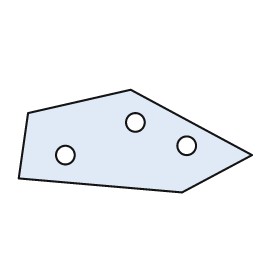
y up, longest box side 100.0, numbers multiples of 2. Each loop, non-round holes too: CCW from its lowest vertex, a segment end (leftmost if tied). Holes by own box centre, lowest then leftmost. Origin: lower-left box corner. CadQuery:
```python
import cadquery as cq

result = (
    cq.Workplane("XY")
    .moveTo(70.0, 0.0)
    .lineTo(100.0, 16.0)
    .lineTo(48.0, 44.0)
    .lineTo(4.0, 34.0)
    .lineTo(0.0, 6.0)
    .close()
    .moveTo(20.0, 16.0)
    .circle(4.0)
    .moveTo(72.0, 20.0)
    .circle(4.0)
    .moveTo(50.0, 30.0)
    .circle(4.0)
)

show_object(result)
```